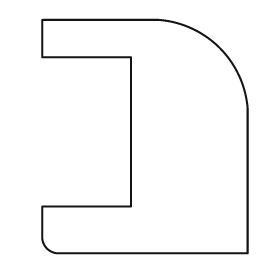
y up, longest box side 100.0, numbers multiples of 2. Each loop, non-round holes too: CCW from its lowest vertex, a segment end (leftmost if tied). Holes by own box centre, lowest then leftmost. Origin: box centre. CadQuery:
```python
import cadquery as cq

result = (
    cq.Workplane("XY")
    .moveTo(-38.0, -50.0)
    .lineTo(44.0, -50.0)
    .lineTo(44.0, 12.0)
    .threePointArc((32.0, 38.0), (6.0, 50.0))
    .lineTo(-44.0, 50.0)
    .lineTo(-44.0, 34.0)
    .lineTo(-6.0, 34.0)
    .lineTo(-6.0, -30.0)
    .lineTo(-44.0, -30.0)
    .lineTo(-44.0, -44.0)
    .threePointArc((-42.0, -48.0), (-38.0, -50.0))
    .close()
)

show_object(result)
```